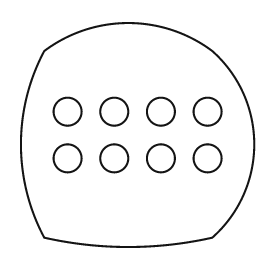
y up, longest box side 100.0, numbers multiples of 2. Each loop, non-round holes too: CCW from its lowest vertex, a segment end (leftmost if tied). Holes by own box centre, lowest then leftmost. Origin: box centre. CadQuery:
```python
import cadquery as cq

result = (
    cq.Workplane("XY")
    .moveTo(-40.0, -44.0)
    .threePointArc((-4.0, -48.0), (32.0, -44.0))
    .threePointArc((50.0, -4.0), (32.0, 36.0))
    .threePointArc((-4.0, 48.0), (-40.0, 36.0))
    .threePointArc((-50.0, -4.0), (-40.0, -44.0))
    .close()
    .moveTo(-30.0, -10.0)
    .circle(6.0)
    .moveTo(-10.0, -10.0)
    .circle(6.0)
    .moveTo(10.0, -10.0)
    .circle(6.0)
    .moveTo(30.0, -10.0)
    .circle(6.0)
    .moveTo(-30.0, 10.0)
    .circle(6.0)
    .moveTo(-10.0, 10.0)
    .circle(6.0)
    .moveTo(10.0, 10.0)
    .circle(6.0)
    .moveTo(30.0, 10.0)
    .circle(6.0)
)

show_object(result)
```